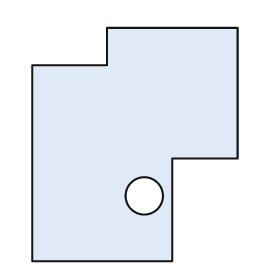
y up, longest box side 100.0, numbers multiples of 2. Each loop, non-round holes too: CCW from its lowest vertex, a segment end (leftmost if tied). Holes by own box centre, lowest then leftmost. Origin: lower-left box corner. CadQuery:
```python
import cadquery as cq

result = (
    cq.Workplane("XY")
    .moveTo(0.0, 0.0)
    .lineTo(60.0, 0.0)
    .lineTo(60.0, 44.0)
    .lineTo(88.0, 44.0)
    .lineTo(88.0, 100.0)
    .lineTo(32.0, 100.0)
    .lineTo(32.0, 84.0)
    .lineTo(0.0, 84.0)
    .close()
    .moveTo(48.0, 28.0)
    .circle(8.0)
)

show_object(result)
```